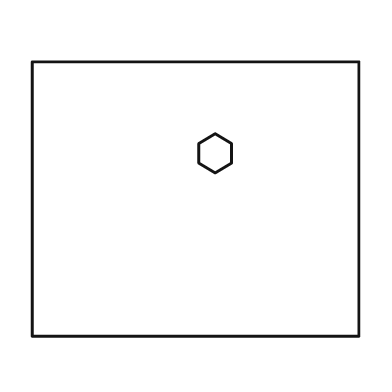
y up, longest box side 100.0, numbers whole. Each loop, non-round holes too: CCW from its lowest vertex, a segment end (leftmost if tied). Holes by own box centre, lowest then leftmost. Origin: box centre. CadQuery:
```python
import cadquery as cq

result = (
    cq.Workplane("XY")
    .moveTo(-50.0, -42.0)
    .lineTo(50.0, -42.0)
    .lineTo(50.0, 42.0)
    .lineTo(-50.0, 42.0)
    .close()
    .moveTo(6.0, 8.0)
    .lineTo(11.0, 11.0)
    .lineTo(11.0, 17.0)
    .lineTo(6.0, 20.0)
    .lineTo(1.0, 17.0)
    .lineTo(1.0, 11.0)
    .close()
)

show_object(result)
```